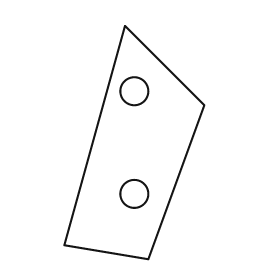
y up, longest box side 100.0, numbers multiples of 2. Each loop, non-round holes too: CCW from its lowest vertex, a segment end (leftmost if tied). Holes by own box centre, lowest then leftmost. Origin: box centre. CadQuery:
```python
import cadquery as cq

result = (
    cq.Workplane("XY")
    .moveTo(6.0, -50.0)
    .lineTo(30.0, 16.0)
    .lineTo(-4.0, 50.0)
    .lineTo(-30.0, -44.0)
    .close()
    .moveTo(0.0, -22.0)
    .circle(6.0)
    .moveTo(0.0, 22.0)
    .circle(6.0)
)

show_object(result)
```